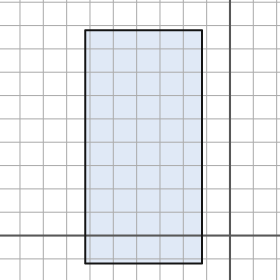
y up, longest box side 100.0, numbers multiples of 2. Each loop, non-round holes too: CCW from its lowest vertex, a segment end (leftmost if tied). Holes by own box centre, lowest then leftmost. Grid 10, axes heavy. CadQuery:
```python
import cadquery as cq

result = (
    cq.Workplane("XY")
    .moveTo(-62.0, -12.0)
    .lineTo(-12.0, -12.0)
    .lineTo(-12.0, 88.0)
    .lineTo(-62.0, 88.0)
    .close()
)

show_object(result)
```